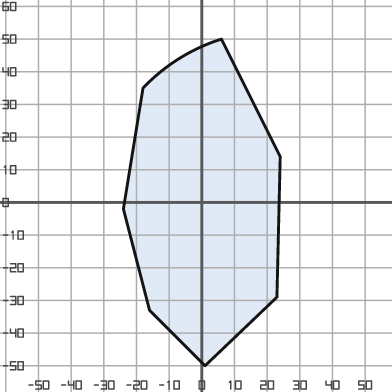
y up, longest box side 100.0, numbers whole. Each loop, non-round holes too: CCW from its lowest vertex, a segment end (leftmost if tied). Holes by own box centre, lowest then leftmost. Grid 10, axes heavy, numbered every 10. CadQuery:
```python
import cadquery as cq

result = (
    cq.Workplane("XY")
    .moveTo(1.0, -50.0)
    .lineTo(23.0, -29.0)
    .lineTo(24.0, 14.0)
    .lineTo(6.0, 50.0)
    .threePointArc((-7.0, 44.0), (-18.0, 35.0))
    .lineTo(-24.0, -2.0)
    .lineTo(-16.0, -33.0)
    .close()
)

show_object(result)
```